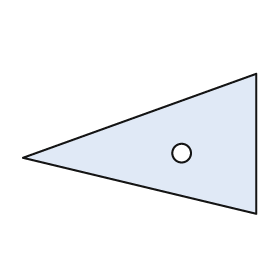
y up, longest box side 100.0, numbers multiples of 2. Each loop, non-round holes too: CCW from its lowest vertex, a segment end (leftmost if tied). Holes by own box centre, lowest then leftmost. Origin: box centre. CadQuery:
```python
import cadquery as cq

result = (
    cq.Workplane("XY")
    .moveTo(50.0, -30.0)
    .lineTo(50.0, 30.0)
    .lineTo(-50.0, -6.0)
    .close()
    .moveTo(18.0, -4.0)
    .circle(4.0)
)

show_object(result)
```